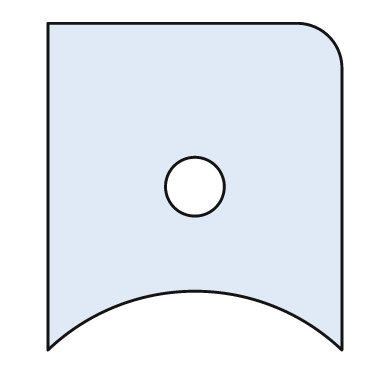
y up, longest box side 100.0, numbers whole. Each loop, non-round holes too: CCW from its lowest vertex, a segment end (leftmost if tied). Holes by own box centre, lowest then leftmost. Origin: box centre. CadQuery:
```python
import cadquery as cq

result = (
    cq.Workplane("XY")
    .moveTo(-45.0, -50.0)
    .threePointArc((0.0, -32.0), (45.0, -50.0))
    .lineTo(45.0, 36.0)
    .threePointArc((41.0, 46.0), (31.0, 50.0))
    .lineTo(-45.0, 50.0)
    .close()
    .moveTo(0.0, 0.0)
    .circle(9.0)
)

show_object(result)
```